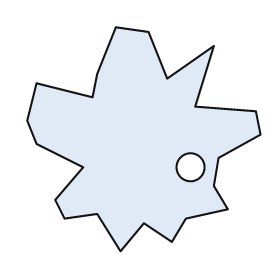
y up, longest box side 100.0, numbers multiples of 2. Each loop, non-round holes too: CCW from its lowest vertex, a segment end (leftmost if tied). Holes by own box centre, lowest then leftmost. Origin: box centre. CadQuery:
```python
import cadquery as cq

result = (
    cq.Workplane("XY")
    .moveTo(-10.0, -48.0)
    .lineTo(0.0, -36.0)
    .lineTo(12.0, -44.0)
    .lineTo(18.0, -34.0)
    .lineTo(36.0, -30.0)
    .lineTo(30.0, -20.0)
    .lineTo(32.0, -8.0)
    .lineTo(50.0, 2.0)
    .lineTo(48.0, 12.0)
    .lineTo(22.0, 14.0)
    .lineTo(30.0, 40.0)
    .lineTo(10.0, 26.0)
    .lineTo(2.0, 46.0)
    .lineTo(-12.0, 48.0)
    .lineTo(-20.0, 28.0)
    .lineTo(-22.0, 18.0)
    .lineTo(-46.0, 24.0)
    .lineTo(-50.0, 8.0)
    .lineTo(-46.0, -2.0)
    .lineTo(-26.0, -12.0)
    .lineTo(-38.0, -26.0)
    .lineTo(-34.0, -34.0)
    .lineTo(-20.0, -32.0)
    .close()
    .moveTo(20.0, -12.0)
    .circle(6.0)
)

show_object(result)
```